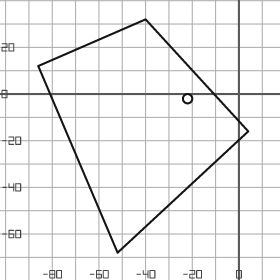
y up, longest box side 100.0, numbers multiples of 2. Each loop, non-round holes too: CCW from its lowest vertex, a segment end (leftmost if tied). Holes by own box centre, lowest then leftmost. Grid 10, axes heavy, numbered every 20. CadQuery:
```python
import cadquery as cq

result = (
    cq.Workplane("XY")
    .moveTo(-52.0, -68.0)
    .lineTo(4.0, -16.0)
    .lineTo(-40.0, 32.0)
    .lineTo(-86.0, 12.0)
    .close()
    .moveTo(-22.0, -2.0)
    .circle(2.0)
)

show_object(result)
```